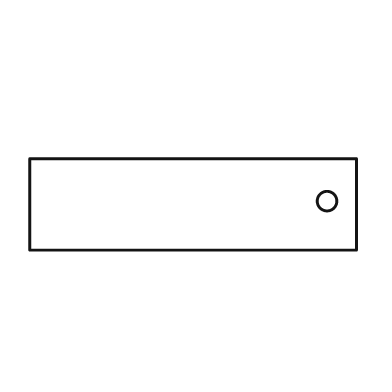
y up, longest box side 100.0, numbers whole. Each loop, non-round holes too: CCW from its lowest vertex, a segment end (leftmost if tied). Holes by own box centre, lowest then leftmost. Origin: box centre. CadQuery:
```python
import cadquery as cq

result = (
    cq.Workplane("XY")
    .moveTo(-50.0, -14.0)
    .lineTo(50.0, -14.0)
    .lineTo(50.0, 14.0)
    .lineTo(-50.0, 14.0)
    .close()
    .moveTo(41.0, 1.0)
    .circle(3.0)
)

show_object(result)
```